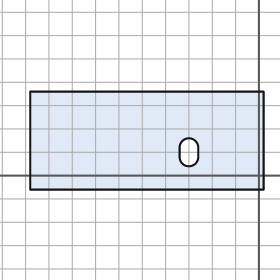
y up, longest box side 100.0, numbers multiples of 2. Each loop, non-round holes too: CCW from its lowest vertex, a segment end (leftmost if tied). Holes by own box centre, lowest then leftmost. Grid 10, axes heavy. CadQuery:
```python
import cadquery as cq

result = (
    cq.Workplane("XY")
    .moveTo(-98.0, -6.0)
    .lineTo(2.0, -6.0)
    .lineTo(2.0, 36.0)
    .lineTo(-98.0, 36.0)
    .close()
    .moveTo(-34.0, 8.0)
    .threePointArc((-30.0, 4.0), (-26.0, 8.0))
    .lineTo(-26.0, 12.0)
    .threePointArc((-30.0, 16.0), (-34.0, 12.0))
    .close()
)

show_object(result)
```